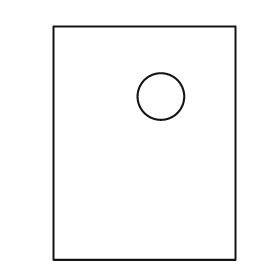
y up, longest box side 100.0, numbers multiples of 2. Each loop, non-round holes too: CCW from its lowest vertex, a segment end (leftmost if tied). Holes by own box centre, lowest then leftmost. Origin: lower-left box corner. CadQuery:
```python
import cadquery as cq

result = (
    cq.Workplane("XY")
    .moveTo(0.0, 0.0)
    .lineTo(78.0, 0.0)
    .lineTo(78.0, 100.0)
    .lineTo(0.0, 100.0)
    .close()
    .moveTo(46.0, 70.0)
    .circle(10.0)
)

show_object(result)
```